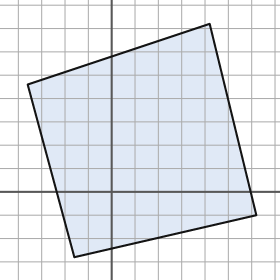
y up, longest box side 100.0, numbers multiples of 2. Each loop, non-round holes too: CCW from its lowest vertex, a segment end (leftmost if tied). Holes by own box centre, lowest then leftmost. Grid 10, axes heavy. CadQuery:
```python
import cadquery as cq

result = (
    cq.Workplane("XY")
    .moveTo(-16.0, -28.0)
    .lineTo(62.0, -10.0)
    .lineTo(42.0, 72.0)
    .lineTo(-36.0, 46.0)
    .close()
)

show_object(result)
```